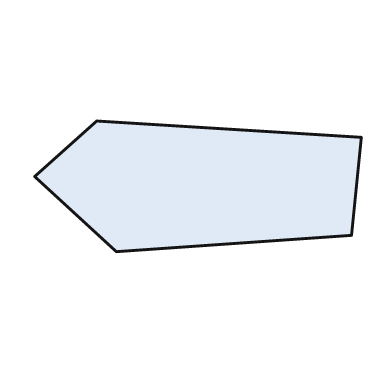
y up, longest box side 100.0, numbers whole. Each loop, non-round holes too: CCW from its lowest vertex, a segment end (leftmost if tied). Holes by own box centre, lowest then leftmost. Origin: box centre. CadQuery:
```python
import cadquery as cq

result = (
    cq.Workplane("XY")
    .moveTo(-25.0, -20.0)
    .lineTo(47.0, -15.0)
    .lineTo(50.0, 15.0)
    .lineTo(-31.0, 20.0)
    .lineTo(-50.0, 3.0)
    .close()
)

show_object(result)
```